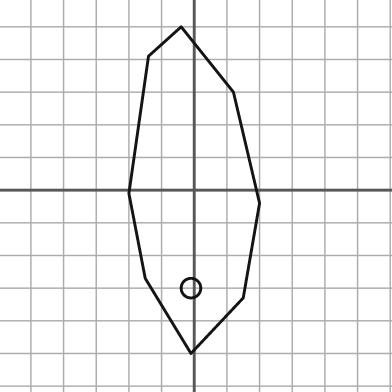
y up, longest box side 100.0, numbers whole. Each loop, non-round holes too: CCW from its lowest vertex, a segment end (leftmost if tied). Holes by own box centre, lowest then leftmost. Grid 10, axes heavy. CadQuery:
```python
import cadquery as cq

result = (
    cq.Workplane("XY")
    .moveTo(-1.0, -50.0)
    .lineTo(15.0, -33.0)
    .lineTo(20.0, -4.0)
    .lineTo(12.0, 30.0)
    .lineTo(-4.0, 50.0)
    .lineTo(-14.0, 41.0)
    .lineTo(-20.0, -1.0)
    .lineTo(-15.0, -27.0)
    .close()
    .moveTo(-1.0, -30.0)
    .circle(3.0)
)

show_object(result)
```